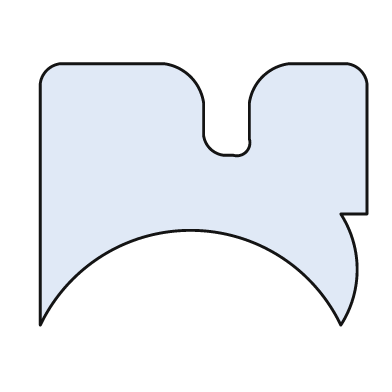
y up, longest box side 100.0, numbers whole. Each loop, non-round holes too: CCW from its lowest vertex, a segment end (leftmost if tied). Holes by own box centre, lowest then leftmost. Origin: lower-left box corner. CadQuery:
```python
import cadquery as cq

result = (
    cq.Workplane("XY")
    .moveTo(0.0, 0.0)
    .threePointArc((46.0, 29.0), (92.0, 0.0))
    .threePointArc((97.0, 17.0), (92.0, 34.0))
    .lineTo(100.0, 34.0)
    .lineTo(100.0, 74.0)
    .threePointArc((98.0, 78.0), (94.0, 80.0))
    .lineTo(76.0, 80.0)
    .threePointArc((68.0, 76.0), (64.0, 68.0))
    .lineTo(64.0, 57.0)
    .threePointArc((63.0, 53.0), (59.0, 52.0))
    .lineTo(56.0, 52.0)
    .threePointArc((52.0, 54.0), (50.0, 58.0))
    .lineTo(50.0, 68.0)
    .threePointArc((46.0, 76.0), (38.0, 80.0))
    .lineTo(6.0, 80.0)
    .threePointArc((2.0, 78.0), (0.0, 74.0))
    .close()
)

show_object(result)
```